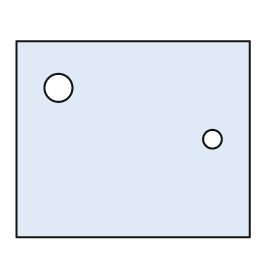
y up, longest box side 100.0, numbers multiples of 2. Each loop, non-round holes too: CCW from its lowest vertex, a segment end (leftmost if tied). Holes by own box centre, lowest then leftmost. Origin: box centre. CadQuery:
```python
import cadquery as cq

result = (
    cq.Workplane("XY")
    .moveTo(-50.0, -42.0)
    .lineTo(50.0, -42.0)
    .lineTo(50.0, 42.0)
    .lineTo(-50.0, 42.0)
    .close()
    .moveTo(34.0, 0.0)
    .circle(4.0)
    .moveTo(-32.0, 22.0)
    .circle(6.0)
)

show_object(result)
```